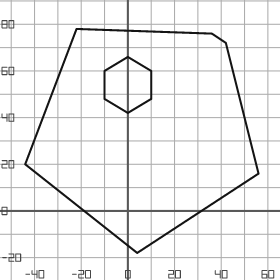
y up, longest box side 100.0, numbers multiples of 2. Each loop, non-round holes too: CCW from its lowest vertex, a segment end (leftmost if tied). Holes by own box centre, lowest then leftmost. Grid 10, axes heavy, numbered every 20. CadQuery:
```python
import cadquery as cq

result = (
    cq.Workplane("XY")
    .moveTo(4.0, -18.0)
    .lineTo(56.0, 16.0)
    .lineTo(42.0, 72.0)
    .lineTo(36.0, 76.0)
    .lineTo(-22.0, 78.0)
    .lineTo(-44.0, 20.0)
    .close()
    .moveTo(0.0, 42.0)
    .lineTo(10.0, 48.0)
    .lineTo(10.0, 60.0)
    .lineTo(0.0, 66.0)
    .lineTo(-10.0, 60.0)
    .lineTo(-10.0, 48.0)
    .close()
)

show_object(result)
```